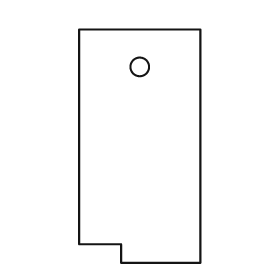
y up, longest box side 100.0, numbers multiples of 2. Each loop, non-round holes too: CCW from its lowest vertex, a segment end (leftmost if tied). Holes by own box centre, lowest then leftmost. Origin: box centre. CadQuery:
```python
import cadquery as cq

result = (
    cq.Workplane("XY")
    .moveTo(-8.0, -50.0)
    .lineTo(26.0, -50.0)
    .lineTo(26.0, 50.0)
    .lineTo(-26.0, 50.0)
    .lineTo(-26.0, -42.0)
    .lineTo(-8.0, -42.0)
    .close()
    .moveTo(0.0, 34.0)
    .circle(4.0)
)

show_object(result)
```